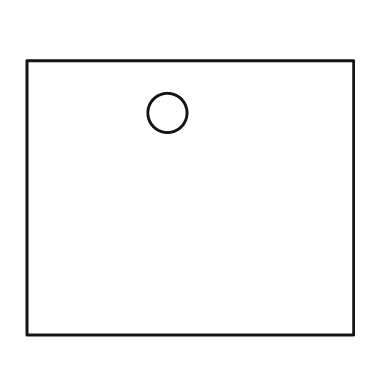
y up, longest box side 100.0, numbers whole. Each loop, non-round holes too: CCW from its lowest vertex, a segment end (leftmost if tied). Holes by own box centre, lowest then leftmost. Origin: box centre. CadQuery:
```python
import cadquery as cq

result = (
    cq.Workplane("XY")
    .moveTo(-50.0, -42.0)
    .lineTo(50.0, -42.0)
    .lineTo(50.0, 42.0)
    .lineTo(-50.0, 42.0)
    .close()
    .moveTo(-7.0, 26.0)
    .circle(6.0)
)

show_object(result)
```